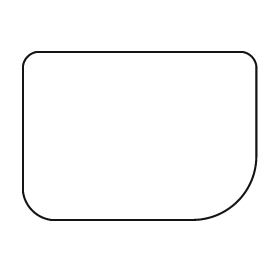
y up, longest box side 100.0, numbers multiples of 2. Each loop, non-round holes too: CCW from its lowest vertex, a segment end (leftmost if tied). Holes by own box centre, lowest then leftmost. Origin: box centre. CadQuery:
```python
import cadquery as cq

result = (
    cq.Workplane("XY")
    .moveTo(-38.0, -36.0)
    .lineTo(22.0, -36.0)
    .threePointArc((42.0, -28.0), (50.0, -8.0))
    .lineTo(50.0, 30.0)
    .threePointArc((48.0, 34.0), (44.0, 36.0))
    .lineTo(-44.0, 36.0)
    .threePointArc((-48.0, 34.0), (-50.0, 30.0))
    .lineTo(-50.0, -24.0)
    .threePointArc((-46.0, -32.0), (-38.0, -36.0))
    .close()
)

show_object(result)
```